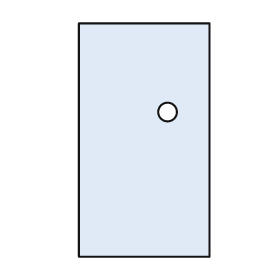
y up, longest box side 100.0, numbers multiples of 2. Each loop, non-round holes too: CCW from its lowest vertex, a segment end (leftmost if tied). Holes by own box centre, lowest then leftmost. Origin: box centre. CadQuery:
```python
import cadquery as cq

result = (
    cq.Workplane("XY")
    .moveTo(-28.0, -50.0)
    .lineTo(28.0, -50.0)
    .lineTo(28.0, 50.0)
    .lineTo(-28.0, 50.0)
    .close()
    .moveTo(10.0, 12.0)
    .circle(4.0)
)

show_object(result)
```